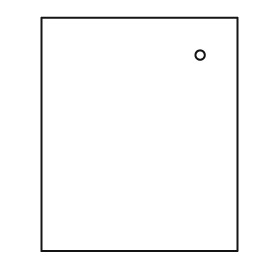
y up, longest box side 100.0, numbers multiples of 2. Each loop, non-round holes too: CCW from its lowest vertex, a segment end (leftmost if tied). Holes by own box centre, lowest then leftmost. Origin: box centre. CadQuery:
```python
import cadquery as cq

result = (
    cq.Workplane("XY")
    .moveTo(-42.0, -50.0)
    .lineTo(42.0, -50.0)
    .lineTo(42.0, 50.0)
    .lineTo(-42.0, 50.0)
    .close()
    .moveTo(26.0, 34.0)
    .circle(2.0)
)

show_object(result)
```